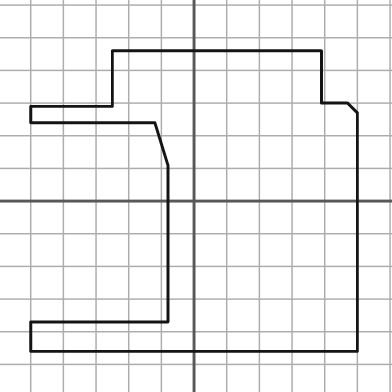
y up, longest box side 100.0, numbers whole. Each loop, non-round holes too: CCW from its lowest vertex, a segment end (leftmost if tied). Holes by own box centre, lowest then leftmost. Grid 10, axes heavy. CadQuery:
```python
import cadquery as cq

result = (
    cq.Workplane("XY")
    .moveTo(-50.0, -46.0)
    .lineTo(50.0, -46.0)
    .lineTo(50.0, 27.0)
    .lineTo(47.0, 30.0)
    .lineTo(39.0, 30.0)
    .lineTo(39.0, 46.0)
    .lineTo(-25.0, 46.0)
    .lineTo(-25.0, 29.0)
    .lineTo(-50.0, 29.0)
    .lineTo(-50.0, 24.0)
    .lineTo(-12.0, 24.0)
    .lineTo(-8.0, 11.0)
    .lineTo(-8.0, -37.0)
    .lineTo(-50.0, -37.0)
    .close()
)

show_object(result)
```